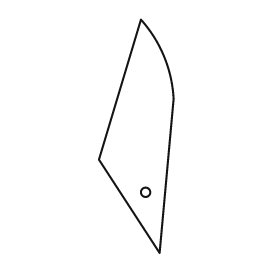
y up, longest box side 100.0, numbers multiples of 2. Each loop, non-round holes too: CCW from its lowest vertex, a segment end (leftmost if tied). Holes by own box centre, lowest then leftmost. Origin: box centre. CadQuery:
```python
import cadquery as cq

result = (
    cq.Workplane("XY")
    .moveTo(10.0, -50.0)
    .lineTo(16.0, 16.0)
    .threePointArc((12.0, 34.0), (2.0, 50.0))
    .lineTo(-16.0, -10.0)
    .close()
    .moveTo(4.0, -24.0)
    .circle(2.0)
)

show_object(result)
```